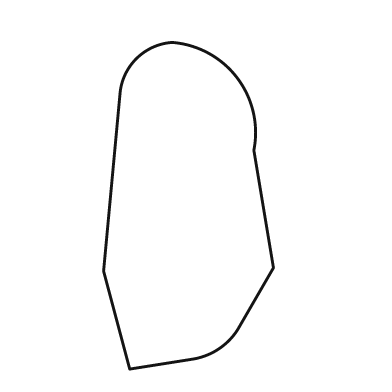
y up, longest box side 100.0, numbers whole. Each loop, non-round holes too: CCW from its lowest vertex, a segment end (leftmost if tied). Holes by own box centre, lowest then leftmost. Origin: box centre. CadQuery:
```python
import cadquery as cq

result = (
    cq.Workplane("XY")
    .moveTo(-18.0, -50.0)
    .lineTo(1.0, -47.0)
    .threePointArc((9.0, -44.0), (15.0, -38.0))
    .lineTo(26.0, -19.0)
    .lineTo(20.0, 17.0)
    .threePointArc((15.0, 39.0), (-5.0, 50.0))
    .threePointArc((-16.0, 45.0), (-21.0, 34.0))
    .lineTo(-26.0, -20.0)
    .close()
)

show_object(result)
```